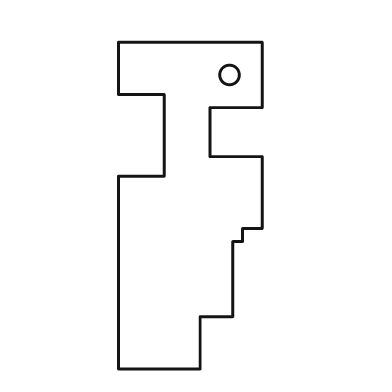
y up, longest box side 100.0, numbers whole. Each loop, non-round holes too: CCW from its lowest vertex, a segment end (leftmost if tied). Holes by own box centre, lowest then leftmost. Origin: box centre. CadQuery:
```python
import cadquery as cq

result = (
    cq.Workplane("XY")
    .moveTo(-22.0, -50.0)
    .lineTo(3.0, -50.0)
    .lineTo(3.0, -34.0)
    .lineTo(13.0, -34.0)
    .lineTo(13.0, -11.0)
    .lineTo(16.0, -11.0)
    .lineTo(16.0, -7.0)
    .lineTo(22.0, -7.0)
    .lineTo(22.0, 15.0)
    .lineTo(6.0, 15.0)
    .lineTo(6.0, 30.0)
    .lineTo(22.0, 30.0)
    .lineTo(22.0, 50.0)
    .lineTo(-22.0, 50.0)
    .lineTo(-22.0, 34.0)
    .lineTo(-8.0, 34.0)
    .lineTo(-8.0, 9.0)
    .lineTo(-22.0, 9.0)
    .close()
    .moveTo(12.0, 40.0)
    .circle(3.0)
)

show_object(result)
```